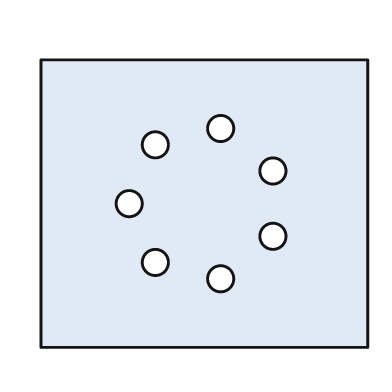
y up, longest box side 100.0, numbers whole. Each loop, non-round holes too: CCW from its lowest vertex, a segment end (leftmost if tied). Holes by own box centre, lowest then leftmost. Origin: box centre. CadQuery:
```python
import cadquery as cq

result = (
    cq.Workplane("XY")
    .moveTo(-50.0, -44.0)
    .lineTo(50.0, -44.0)
    .lineTo(50.0, 44.0)
    .lineTo(-50.0, 44.0)
    .close()
    .moveTo(5.0, -23.0)
    .circle(4.0)
    .moveTo(-15.0, -18.0)
    .circle(4.0)
    .moveTo(21.0, -10.0)
    .circle(4.0)
    .moveTo(-23.0, 0.0)
    .circle(4.0)
    .moveTo(21.0, 10.0)
    .circle(4.0)
    .moveTo(-15.0, 18.0)
    .circle(4.0)
    .moveTo(5.0, 23.0)
    .circle(4.0)
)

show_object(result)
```